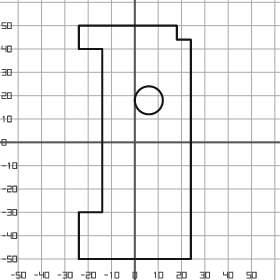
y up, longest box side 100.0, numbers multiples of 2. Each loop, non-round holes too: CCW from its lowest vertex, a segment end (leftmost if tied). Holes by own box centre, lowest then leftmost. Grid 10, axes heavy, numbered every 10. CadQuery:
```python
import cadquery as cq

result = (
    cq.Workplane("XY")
    .moveTo(-24.0, -50.0)
    .lineTo(24.0, -50.0)
    .lineTo(24.0, 44.0)
    .lineTo(18.0, 44.0)
    .lineTo(18.0, 50.0)
    .lineTo(-24.0, 50.0)
    .lineTo(-24.0, 40.0)
    .lineTo(-14.0, 40.0)
    .lineTo(-14.0, -30.0)
    .lineTo(-24.0, -30.0)
    .close()
    .moveTo(6.0, 18.0)
    .circle(6.0)
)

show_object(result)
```